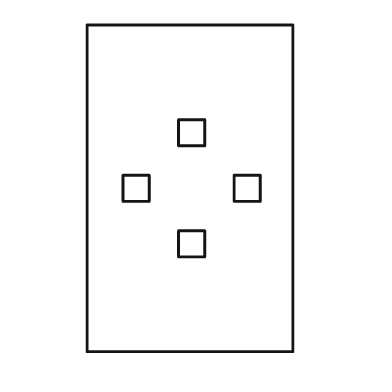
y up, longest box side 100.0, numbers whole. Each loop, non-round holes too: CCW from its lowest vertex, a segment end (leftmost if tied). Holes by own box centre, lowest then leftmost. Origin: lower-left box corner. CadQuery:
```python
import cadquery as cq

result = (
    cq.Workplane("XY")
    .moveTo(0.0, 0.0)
    .lineTo(63.0, 0.0)
    .lineTo(63.0, 100.0)
    .lineTo(0.0, 100.0)
    .close()
    .moveTo(28.0, 29.0)
    .lineTo(36.0, 29.0)
    .lineTo(36.0, 37.0)
    .lineTo(28.0, 37.0)
    .close()
    .moveTo(11.0, 46.0)
    .lineTo(19.0, 46.0)
    .lineTo(19.0, 54.0)
    .lineTo(11.0, 54.0)
    .close()
    .moveTo(45.0, 46.0)
    .lineTo(53.0, 46.0)
    .lineTo(53.0, 54.0)
    .lineTo(45.0, 54.0)
    .close()
    .moveTo(28.0, 63.0)
    .lineTo(36.0, 63.0)
    .lineTo(36.0, 71.0)
    .lineTo(28.0, 71.0)
    .close()
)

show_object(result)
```